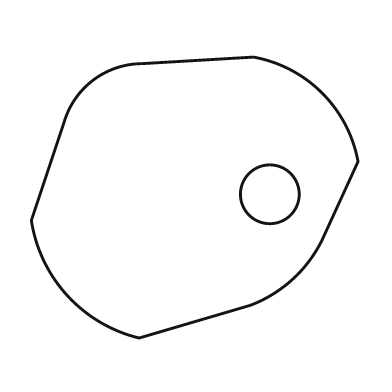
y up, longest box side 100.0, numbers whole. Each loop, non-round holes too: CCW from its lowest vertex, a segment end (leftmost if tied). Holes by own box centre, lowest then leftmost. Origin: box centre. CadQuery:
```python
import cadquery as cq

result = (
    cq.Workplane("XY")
    .moveTo(-17.0, -43.0)
    .lineTo(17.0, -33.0)
    .threePointArc((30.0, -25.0), (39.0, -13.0))
    .lineTo(50.0, 11.0)
    .threePointArc((39.0, 32.0), (18.0, 43.0))
    .lineTo(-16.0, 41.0)
    .threePointArc((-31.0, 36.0), (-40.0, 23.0))
    .lineTo(-50.0, -7.0)
    .threePointArc((-39.0, -30.0), (-17.0, -43.0))
    .close()
    .moveTo(23.0, 1.0)
    .circle(9.0)
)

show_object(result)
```